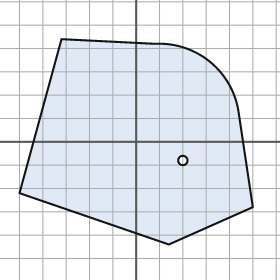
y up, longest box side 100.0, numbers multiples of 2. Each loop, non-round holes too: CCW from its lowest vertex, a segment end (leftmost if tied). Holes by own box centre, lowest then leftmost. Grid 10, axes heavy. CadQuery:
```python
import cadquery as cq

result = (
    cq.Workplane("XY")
    .moveTo(14.0, -44.0)
    .lineTo(50.0, -28.0)
    .lineTo(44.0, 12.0)
    .threePointArc((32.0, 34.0), (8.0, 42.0))
    .lineTo(-32.0, 44.0)
    .lineTo(-50.0, -22.0)
    .close()
    .moveTo(20.0, -8.0)
    .circle(2.0)
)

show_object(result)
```